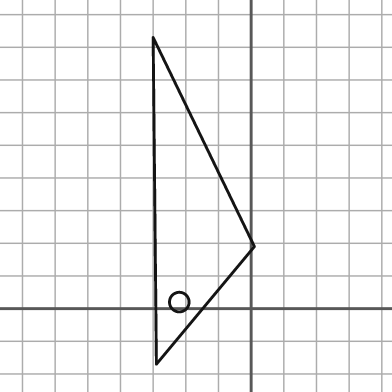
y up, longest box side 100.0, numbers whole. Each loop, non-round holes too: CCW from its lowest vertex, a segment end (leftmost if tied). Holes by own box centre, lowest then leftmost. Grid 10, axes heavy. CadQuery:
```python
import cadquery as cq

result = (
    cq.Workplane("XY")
    .moveTo(-29.0, -17.0)
    .lineTo(1.0, 19.0)
    .lineTo(-30.0, 83.0)
    .close()
    .moveTo(-22.0, 2.0)
    .circle(3.0)
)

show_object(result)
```